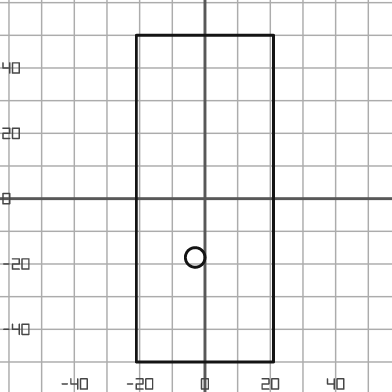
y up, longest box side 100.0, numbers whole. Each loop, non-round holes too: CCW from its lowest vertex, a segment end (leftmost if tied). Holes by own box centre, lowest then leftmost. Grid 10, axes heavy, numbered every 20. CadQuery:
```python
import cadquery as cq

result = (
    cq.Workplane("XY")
    .moveTo(-21.0, -50.0)
    .lineTo(21.0, -50.0)
    .lineTo(21.0, 50.0)
    .lineTo(-21.0, 50.0)
    .close()
    .moveTo(-3.0, -18.0)
    .circle(3.0)
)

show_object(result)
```